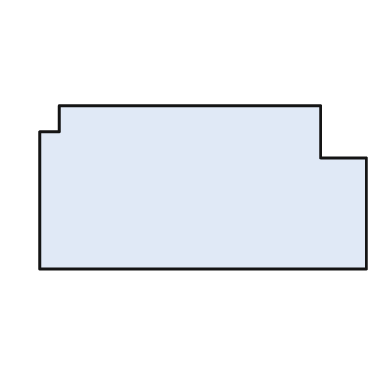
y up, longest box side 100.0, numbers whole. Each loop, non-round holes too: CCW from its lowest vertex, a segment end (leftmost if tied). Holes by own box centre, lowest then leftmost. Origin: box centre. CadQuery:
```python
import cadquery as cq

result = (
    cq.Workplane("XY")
    .moveTo(-50.0, -25.0)
    .lineTo(50.0, -25.0)
    .lineTo(50.0, 9.0)
    .lineTo(36.0, 9.0)
    .lineTo(36.0, 25.0)
    .lineTo(-44.0, 25.0)
    .lineTo(-44.0, 17.0)
    .lineTo(-50.0, 17.0)
    .close()
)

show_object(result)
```